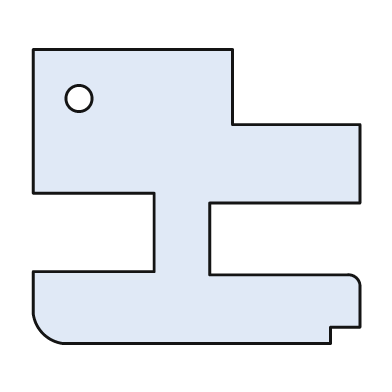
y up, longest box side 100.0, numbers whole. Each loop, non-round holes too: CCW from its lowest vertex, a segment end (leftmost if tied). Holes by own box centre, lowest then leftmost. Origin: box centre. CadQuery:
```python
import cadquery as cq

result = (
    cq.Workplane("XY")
    .moveTo(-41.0, -45.0)
    .lineTo(41.0, -45.0)
    .lineTo(41.0, -40.0)
    .lineTo(50.0, -40.0)
    .lineTo(50.0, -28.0)
    .threePointArc((49.0, -25.0), (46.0, -24.0))
    .lineTo(4.0, -24.0)
    .lineTo(4.0, -2.0)
    .lineTo(50.0, -2.0)
    .lineTo(50.0, 22.0)
    .lineTo(11.0, 22.0)
    .lineTo(11.0, 45.0)
    .lineTo(-50.0, 45.0)
    .lineTo(-50.0, 1.0)
    .lineTo(-13.0, 1.0)
    .lineTo(-13.0, -23.0)
    .lineTo(-50.0, -23.0)
    .lineTo(-50.0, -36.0)
    .threePointArc((-47.0, -42.0), (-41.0, -45.0))
    .close()
    .moveTo(-36.0, 30.0)
    .circle(4.0)
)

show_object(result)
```